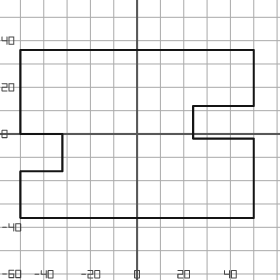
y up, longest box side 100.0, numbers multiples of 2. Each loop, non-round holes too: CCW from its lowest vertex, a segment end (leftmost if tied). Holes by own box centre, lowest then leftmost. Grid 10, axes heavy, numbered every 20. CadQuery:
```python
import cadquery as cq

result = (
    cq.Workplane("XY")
    .moveTo(-50.0, -36.0)
    .lineTo(50.0, -36.0)
    .lineTo(50.0, -2.0)
    .lineTo(24.0, -2.0)
    .lineTo(24.0, 12.0)
    .lineTo(50.0, 12.0)
    .lineTo(50.0, 36.0)
    .lineTo(-50.0, 36.0)
    .lineTo(-50.0, 0.0)
    .lineTo(-32.0, 0.0)
    .lineTo(-32.0, -16.0)
    .lineTo(-50.0, -16.0)
    .close()
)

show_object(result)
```